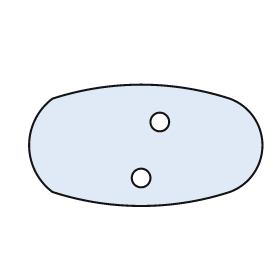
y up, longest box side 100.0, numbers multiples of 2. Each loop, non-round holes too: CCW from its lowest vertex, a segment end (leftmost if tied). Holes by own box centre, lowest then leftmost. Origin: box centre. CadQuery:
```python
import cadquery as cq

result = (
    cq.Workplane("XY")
    .moveTo(-40.0, -20.0)
    .threePointArc((-2.0, -26.0), (36.0, -20.0))
    .threePointArc((50.0, 0.0), (36.0, 20.0))
    .threePointArc((-2.0, 26.0), (-40.0, 20.0))
    .threePointArc((-50.0, 0.0), (-40.0, -20.0))
    .close()
    .moveTo(-2.0, -14.0)
    .circle(4.0)
    .moveTo(6.0, 10.0)
    .circle(4.0)
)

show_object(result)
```